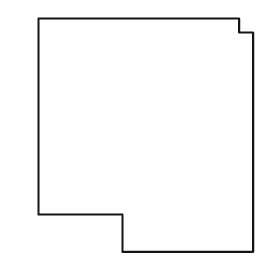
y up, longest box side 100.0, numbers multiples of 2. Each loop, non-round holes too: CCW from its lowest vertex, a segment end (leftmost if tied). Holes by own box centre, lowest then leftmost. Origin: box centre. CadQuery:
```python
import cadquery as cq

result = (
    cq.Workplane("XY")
    .moveTo(-10.0, -50.0)
    .lineTo(46.0, -50.0)
    .lineTo(46.0, 44.0)
    .lineTo(40.0, 44.0)
    .lineTo(40.0, 50.0)
    .lineTo(-46.0, 50.0)
    .lineTo(-46.0, -34.0)
    .lineTo(-10.0, -34.0)
    .close()
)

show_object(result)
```